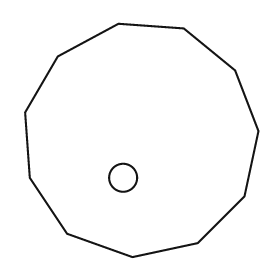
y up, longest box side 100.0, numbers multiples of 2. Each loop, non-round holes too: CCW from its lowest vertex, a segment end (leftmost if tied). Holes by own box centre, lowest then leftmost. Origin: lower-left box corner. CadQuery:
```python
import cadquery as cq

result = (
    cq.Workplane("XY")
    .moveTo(46.0, 0.0)
    .lineTo(74.0, 6.0)
    .lineTo(94.0, 26.0)
    .lineTo(100.0, 54.0)
    .lineTo(90.0, 80.0)
    .lineTo(68.0, 98.0)
    .lineTo(40.0, 100.0)
    .lineTo(14.0, 86.0)
    .lineTo(0.0, 62.0)
    .lineTo(2.0, 34.0)
    .lineTo(18.0, 10.0)
    .close()
    .moveTo(42.0, 34.0)
    .circle(6.0)
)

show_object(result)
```